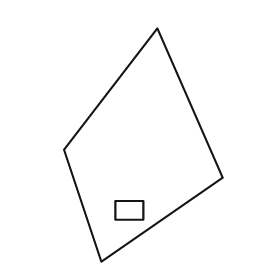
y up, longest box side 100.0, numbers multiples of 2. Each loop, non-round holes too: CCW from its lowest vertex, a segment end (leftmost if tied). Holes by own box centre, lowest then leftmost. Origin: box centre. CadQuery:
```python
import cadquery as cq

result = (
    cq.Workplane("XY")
    .moveTo(-18.0, -50.0)
    .lineTo(34.0, -14.0)
    .lineTo(6.0, 50.0)
    .lineTo(-34.0, -2.0)
    .close()
    .moveTo(-12.0, -32.0)
    .lineTo(0.0, -32.0)
    .lineTo(0.0, -24.0)
    .lineTo(-12.0, -24.0)
    .close()
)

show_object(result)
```